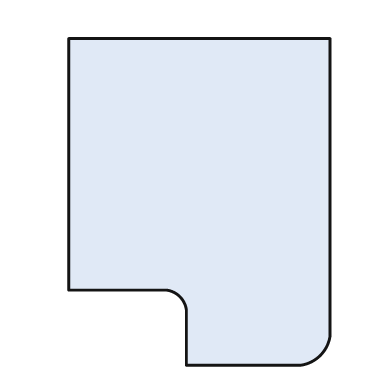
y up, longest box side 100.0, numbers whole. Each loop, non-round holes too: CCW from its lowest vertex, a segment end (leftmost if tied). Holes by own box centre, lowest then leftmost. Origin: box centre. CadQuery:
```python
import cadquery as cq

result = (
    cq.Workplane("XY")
    .moveTo(-4.0, -50.0)
    .lineTo(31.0, -50.0)
    .threePointArc((37.0, -47.0), (40.0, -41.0))
    .lineTo(40.0, 50.0)
    .lineTo(-40.0, 50.0)
    .lineTo(-40.0, -27.0)
    .lineTo(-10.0, -27.0)
    .threePointArc((-6.0, -29.0), (-4.0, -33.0))
    .close()
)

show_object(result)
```